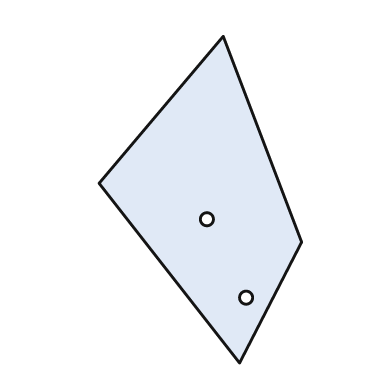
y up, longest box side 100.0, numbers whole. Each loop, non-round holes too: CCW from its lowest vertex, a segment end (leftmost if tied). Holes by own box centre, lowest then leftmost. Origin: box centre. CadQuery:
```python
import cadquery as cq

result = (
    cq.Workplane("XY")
    .moveTo(12.0, -50.0)
    .lineTo(31.0, -13.0)
    .lineTo(7.0, 50.0)
    .lineTo(-31.0, 5.0)
    .close()
    .moveTo(14.0, -30.0)
    .circle(2.0)
    .moveTo(2.0, -6.0)
    .circle(2.0)
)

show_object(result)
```